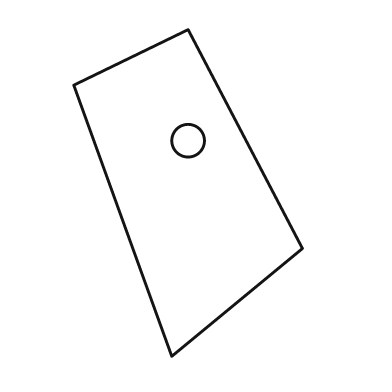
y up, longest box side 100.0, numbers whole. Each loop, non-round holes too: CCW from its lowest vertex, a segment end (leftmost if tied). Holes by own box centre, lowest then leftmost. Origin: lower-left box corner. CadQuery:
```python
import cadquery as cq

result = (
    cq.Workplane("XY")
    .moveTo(30.0, 0.0)
    .lineTo(70.0, 33.0)
    .lineTo(35.0, 100.0)
    .lineTo(0.0, 83.0)
    .close()
    .moveTo(35.0, 66.0)
    .circle(5.0)
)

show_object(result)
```